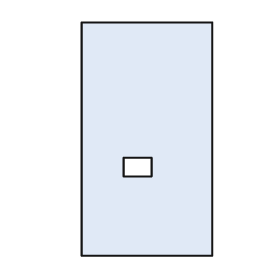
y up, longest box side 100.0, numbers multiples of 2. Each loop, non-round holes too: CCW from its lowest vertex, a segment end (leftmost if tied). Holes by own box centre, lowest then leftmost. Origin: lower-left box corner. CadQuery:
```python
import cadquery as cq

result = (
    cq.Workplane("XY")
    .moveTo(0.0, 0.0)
    .lineTo(56.0, 0.0)
    .lineTo(56.0, 100.0)
    .lineTo(0.0, 100.0)
    .close()
    .moveTo(18.0, 34.0)
    .lineTo(30.0, 34.0)
    .lineTo(30.0, 42.0)
    .lineTo(18.0, 42.0)
    .close()
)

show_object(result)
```